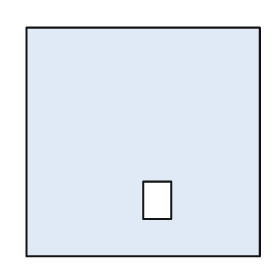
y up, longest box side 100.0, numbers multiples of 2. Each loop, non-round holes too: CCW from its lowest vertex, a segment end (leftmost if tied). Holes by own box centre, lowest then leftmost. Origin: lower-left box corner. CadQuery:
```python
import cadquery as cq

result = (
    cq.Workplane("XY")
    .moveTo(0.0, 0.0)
    .lineTo(100.0, 0.0)
    .lineTo(100.0, 98.0)
    .lineTo(0.0, 98.0)
    .close()
    .moveTo(50.0, 16.0)
    .lineTo(62.0, 16.0)
    .lineTo(62.0, 32.0)
    .lineTo(50.0, 32.0)
    .close()
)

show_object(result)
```